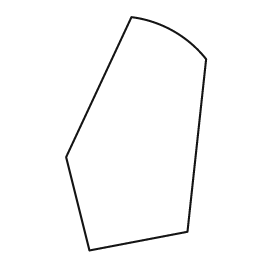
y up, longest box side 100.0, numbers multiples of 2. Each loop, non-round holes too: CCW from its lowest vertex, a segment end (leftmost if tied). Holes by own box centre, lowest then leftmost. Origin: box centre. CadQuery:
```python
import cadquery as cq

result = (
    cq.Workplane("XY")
    .moveTo(-20.0, -50.0)
    .lineTo(22.0, -42.0)
    .lineTo(30.0, 32.0)
    .threePointArc((16.0, 44.0), (-2.0, 50.0))
    .lineTo(-30.0, -10.0)
    .close()
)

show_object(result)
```